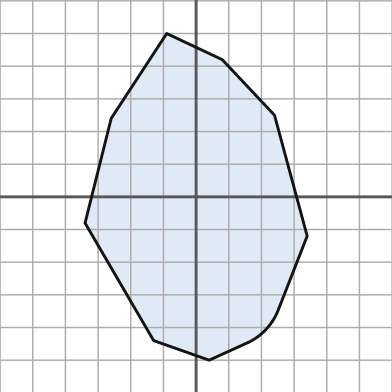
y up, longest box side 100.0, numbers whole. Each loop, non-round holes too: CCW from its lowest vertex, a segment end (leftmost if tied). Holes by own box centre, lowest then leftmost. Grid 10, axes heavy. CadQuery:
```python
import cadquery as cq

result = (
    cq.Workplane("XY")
    .moveTo(4.0, -50.0)
    .lineTo(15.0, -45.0)
    .threePointArc((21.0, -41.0), (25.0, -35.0))
    .lineTo(34.0, -12.0)
    .lineTo(24.0, 25.0)
    .lineTo(8.0, 42.0)
    .lineTo(-9.0, 50.0)
    .lineTo(-26.0, 24.0)
    .lineTo(-34.0, -8.0)
    .lineTo(-13.0, -44.0)
    .close()
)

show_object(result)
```